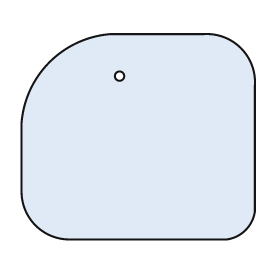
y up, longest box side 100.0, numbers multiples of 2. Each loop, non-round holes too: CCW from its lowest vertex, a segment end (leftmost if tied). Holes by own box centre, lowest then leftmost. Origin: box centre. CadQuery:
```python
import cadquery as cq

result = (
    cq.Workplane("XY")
    .moveTo(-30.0, -44.0)
    .lineTo(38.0, -44.0)
    .threePointArc((46.0, -40.0), (50.0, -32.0))
    .lineTo(50.0, 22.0)
    .threePointArc((44.0, 38.0), (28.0, 44.0))
    .lineTo(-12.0, 44.0)
    .threePointArc((-38.0, 32.0), (-50.0, 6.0))
    .lineTo(-50.0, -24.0)
    .threePointArc((-44.0, -38.0), (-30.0, -44.0))
    .close()
    .moveTo(-8.0, 26.0)
    .circle(2.0)
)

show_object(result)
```